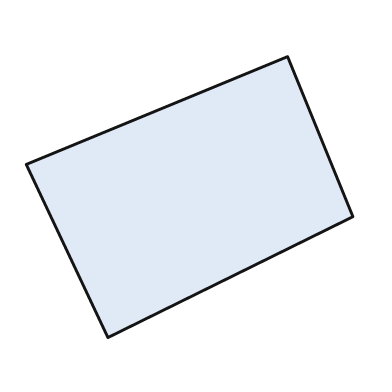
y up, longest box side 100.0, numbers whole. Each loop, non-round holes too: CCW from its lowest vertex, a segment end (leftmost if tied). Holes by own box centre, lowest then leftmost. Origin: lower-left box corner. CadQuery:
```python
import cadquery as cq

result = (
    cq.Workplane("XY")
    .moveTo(25.0, 0.0)
    .lineTo(100.0, 37.0)
    .lineTo(80.0, 86.0)
    .lineTo(0.0, 53.0)
    .close()
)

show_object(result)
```